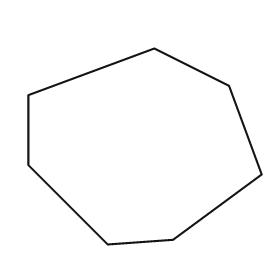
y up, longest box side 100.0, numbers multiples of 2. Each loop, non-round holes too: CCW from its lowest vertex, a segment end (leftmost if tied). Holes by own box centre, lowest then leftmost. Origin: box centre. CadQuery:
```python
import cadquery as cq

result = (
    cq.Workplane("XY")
    .moveTo(-16.0, -42.0)
    .lineTo(12.0, -40.0)
    .lineTo(50.0, -12.0)
    .lineTo(36.0, 26.0)
    .lineTo(4.0, 42.0)
    .lineTo(-50.0, 22.0)
    .lineTo(-50.0, -8.0)
    .close()
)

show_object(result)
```